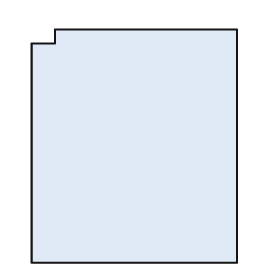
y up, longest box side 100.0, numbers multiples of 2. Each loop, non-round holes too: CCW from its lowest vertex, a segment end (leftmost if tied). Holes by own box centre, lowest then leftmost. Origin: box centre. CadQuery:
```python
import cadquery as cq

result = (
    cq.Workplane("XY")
    .moveTo(-44.0, -50.0)
    .lineTo(44.0, -50.0)
    .lineTo(44.0, 50.0)
    .lineTo(-34.0, 50.0)
    .lineTo(-34.0, 44.0)
    .lineTo(-44.0, 44.0)
    .close()
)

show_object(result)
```